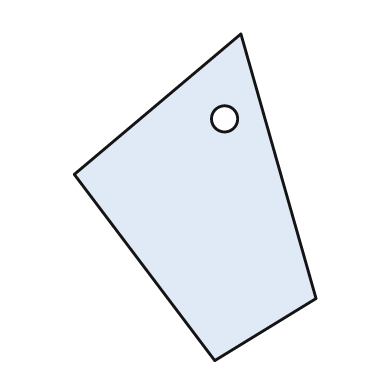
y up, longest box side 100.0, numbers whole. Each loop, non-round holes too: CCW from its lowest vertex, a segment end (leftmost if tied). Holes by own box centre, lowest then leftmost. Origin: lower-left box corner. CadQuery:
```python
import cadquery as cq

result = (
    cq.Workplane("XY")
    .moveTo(43.0, 0.0)
    .lineTo(74.0, 19.0)
    .lineTo(51.0, 100.0)
    .lineTo(0.0, 57.0)
    .close()
    .moveTo(46.0, 74.0)
    .circle(4.0)
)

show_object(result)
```